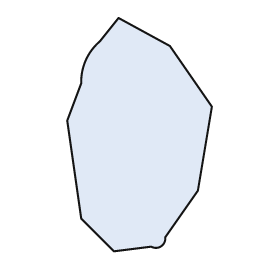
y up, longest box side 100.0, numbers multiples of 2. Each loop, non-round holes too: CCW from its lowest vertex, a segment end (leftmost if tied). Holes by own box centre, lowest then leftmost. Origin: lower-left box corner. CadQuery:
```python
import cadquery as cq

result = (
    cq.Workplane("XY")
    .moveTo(20.0, 0.0)
    .lineTo(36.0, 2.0)
    .threePointArc((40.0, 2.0), (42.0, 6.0))
    .lineTo(56.0, 26.0)
    .lineTo(62.0, 62.0)
    .lineTo(44.0, 88.0)
    .lineTo(22.0, 100.0)
    .lineTo(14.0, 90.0)
    .threePointArc((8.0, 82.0), (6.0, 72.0))
    .lineTo(0.0, 56.0)
    .lineTo(6.0, 14.0)
    .close()
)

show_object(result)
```